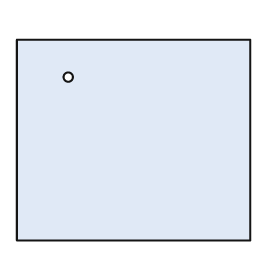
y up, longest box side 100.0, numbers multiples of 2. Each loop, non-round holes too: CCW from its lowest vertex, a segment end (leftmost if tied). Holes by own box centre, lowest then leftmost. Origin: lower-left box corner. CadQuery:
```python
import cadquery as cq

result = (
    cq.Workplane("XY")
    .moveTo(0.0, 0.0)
    .lineTo(100.0, 0.0)
    .lineTo(100.0, 86.0)
    .lineTo(0.0, 86.0)
    .close()
    .moveTo(22.0, 70.0)
    .circle(2.0)
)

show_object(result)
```